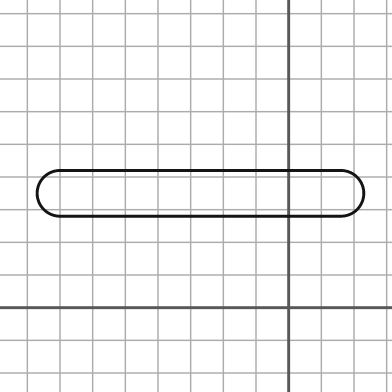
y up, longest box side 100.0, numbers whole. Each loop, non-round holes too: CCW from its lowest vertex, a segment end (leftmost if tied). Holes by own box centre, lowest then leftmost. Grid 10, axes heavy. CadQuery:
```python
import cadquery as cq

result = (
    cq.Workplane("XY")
    .moveTo(-70.0, 28.0)
    .lineTo(16.0, 28.0)
    .threePointArc((23.0, 35.0), (16.0, 42.0))
    .lineTo(-70.0, 42.0)
    .threePointArc((-77.0, 35.0), (-70.0, 28.0))
    .close()
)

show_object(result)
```